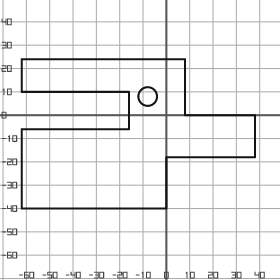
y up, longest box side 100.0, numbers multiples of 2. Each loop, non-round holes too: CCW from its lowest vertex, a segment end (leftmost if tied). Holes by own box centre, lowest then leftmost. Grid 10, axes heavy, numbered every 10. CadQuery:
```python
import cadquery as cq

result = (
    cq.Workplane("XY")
    .moveTo(-62.0, -40.0)
    .lineTo(0.0, -40.0)
    .lineTo(0.0, -18.0)
    .lineTo(38.0, -18.0)
    .lineTo(38.0, 0.0)
    .lineTo(8.0, 0.0)
    .lineTo(8.0, 24.0)
    .lineTo(-62.0, 24.0)
    .lineTo(-62.0, 10.0)
    .lineTo(-16.0, 10.0)
    .lineTo(-16.0, -6.0)
    .lineTo(-62.0, -6.0)
    .close()
    .moveTo(-8.0, 8.0)
    .circle(4.0)
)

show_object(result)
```